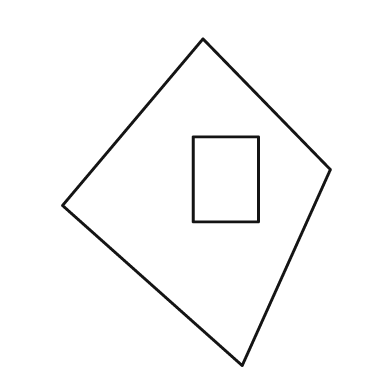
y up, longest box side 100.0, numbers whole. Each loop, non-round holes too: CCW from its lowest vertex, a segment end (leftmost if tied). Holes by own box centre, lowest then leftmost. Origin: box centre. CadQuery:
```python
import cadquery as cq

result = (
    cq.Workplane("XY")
    .moveTo(14.0, -50.0)
    .lineTo(41.0, 10.0)
    .lineTo(2.0, 50.0)
    .lineTo(-41.0, -1.0)
    .close()
    .moveTo(-1.0, -6.0)
    .lineTo(19.0, -6.0)
    .lineTo(19.0, 20.0)
    .lineTo(-1.0, 20.0)
    .close()
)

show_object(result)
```